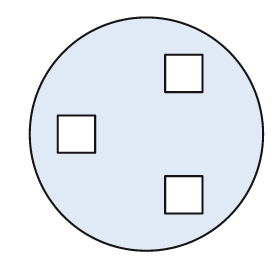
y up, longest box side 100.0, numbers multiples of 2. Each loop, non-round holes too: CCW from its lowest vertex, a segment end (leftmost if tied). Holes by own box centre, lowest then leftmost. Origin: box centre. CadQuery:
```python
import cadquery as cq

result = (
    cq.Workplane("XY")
    .moveTo(0.0, 0.0)
    .circle(50.0)
    .moveTo(8.0, -34.0)
    .lineTo(24.0, -34.0)
    .lineTo(24.0, -18.0)
    .lineTo(8.0, -18.0)
    .close()
    .moveTo(-38.0, -8.0)
    .lineTo(-22.0, -8.0)
    .lineTo(-22.0, 8.0)
    .lineTo(-38.0, 8.0)
    .close()
    .moveTo(8.0, 18.0)
    .lineTo(24.0, 18.0)
    .lineTo(24.0, 34.0)
    .lineTo(8.0, 34.0)
    .close()
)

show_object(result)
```